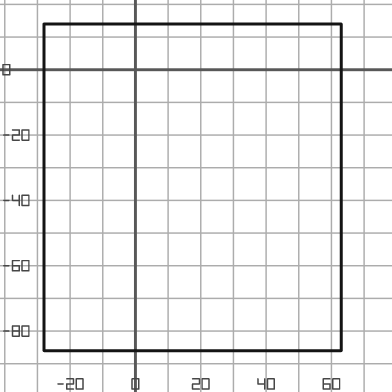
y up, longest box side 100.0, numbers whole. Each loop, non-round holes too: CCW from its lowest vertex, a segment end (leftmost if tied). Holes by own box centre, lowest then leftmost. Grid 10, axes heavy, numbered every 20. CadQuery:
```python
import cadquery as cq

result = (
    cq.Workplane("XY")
    .moveTo(-28.0, -86.0)
    .lineTo(63.0, -86.0)
    .lineTo(63.0, 14.0)
    .lineTo(-28.0, 14.0)
    .close()
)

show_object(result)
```